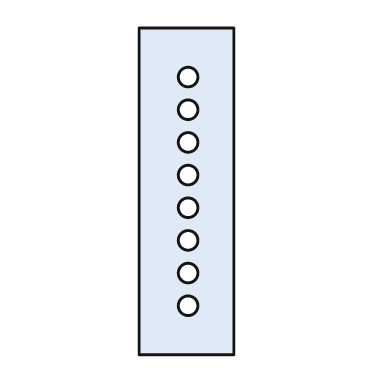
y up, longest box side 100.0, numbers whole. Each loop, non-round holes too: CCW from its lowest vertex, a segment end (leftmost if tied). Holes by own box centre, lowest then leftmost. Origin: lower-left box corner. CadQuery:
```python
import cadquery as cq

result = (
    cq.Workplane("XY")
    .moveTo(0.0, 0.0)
    .lineTo(29.0, 0.0)
    .lineTo(29.0, 100.0)
    .lineTo(0.0, 100.0)
    .close()
    .moveTo(15.0, 15.0)
    .circle(3.0)
    .moveTo(15.0, 25.0)
    .circle(3.0)
    .moveTo(15.0, 35.0)
    .circle(3.0)
    .moveTo(15.0, 45.0)
    .circle(3.0)
    .moveTo(15.0, 55.0)
    .circle(3.0)
    .moveTo(15.0, 65.0)
    .circle(3.0)
    .moveTo(15.0, 75.0)
    .circle(3.0)
    .moveTo(15.0, 85.0)
    .circle(3.0)
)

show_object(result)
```